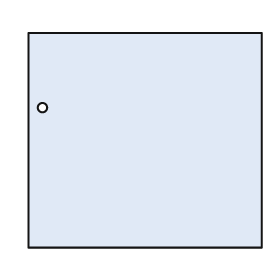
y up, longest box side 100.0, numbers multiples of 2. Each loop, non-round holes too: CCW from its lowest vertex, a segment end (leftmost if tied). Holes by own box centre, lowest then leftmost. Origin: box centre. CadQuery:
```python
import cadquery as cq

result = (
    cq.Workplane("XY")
    .moveTo(-50.0, -46.0)
    .lineTo(50.0, -46.0)
    .lineTo(50.0, 46.0)
    .lineTo(-50.0, 46.0)
    .close()
    .moveTo(-44.0, 14.0)
    .circle(2.0)
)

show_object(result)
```